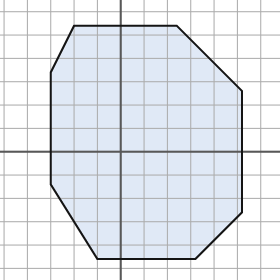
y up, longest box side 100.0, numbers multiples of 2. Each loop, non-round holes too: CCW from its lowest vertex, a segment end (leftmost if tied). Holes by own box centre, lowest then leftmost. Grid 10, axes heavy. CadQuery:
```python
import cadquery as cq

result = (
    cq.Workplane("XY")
    .moveTo(-10.0, -46.0)
    .lineTo(32.0, -46.0)
    .lineTo(52.0, -26.0)
    .lineTo(52.0, 26.0)
    .lineTo(24.0, 54.0)
    .lineTo(-20.0, 54.0)
    .lineTo(-30.0, 34.0)
    .lineTo(-30.0, -14.0)
    .close()
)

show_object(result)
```